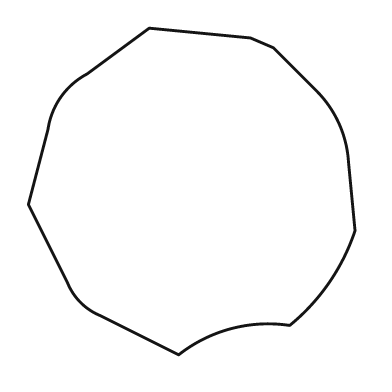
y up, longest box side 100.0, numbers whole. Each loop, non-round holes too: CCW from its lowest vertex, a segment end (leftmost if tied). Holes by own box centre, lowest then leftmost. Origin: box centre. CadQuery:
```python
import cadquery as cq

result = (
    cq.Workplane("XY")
    .moveTo(-4.0, -50.0)
    .threePointArc((12.0, -42.0), (30.0, -41.0))
    .threePointArc((42.0, -28.0), (50.0, -12.0))
    .lineTo(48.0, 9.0)
    .threePointArc((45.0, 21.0), (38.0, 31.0))
    .lineTo(25.0, 44.0)
    .lineTo(18.0, 47.0)
    .lineTo(-13.0, 50.0)
    .lineTo(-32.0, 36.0)
    .threePointArc((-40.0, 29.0), (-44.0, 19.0))
    .lineTo(-50.0, -4.0)
    .lineTo(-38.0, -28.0)
    .threePointArc((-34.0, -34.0), (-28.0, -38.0))
    .close()
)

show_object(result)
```